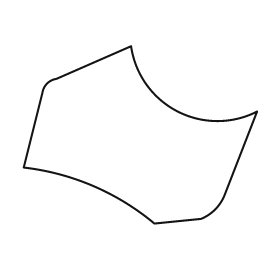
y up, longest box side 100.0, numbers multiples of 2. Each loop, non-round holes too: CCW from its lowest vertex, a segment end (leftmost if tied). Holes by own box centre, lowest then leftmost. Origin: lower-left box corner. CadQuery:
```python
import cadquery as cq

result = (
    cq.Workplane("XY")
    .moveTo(56.0, 0.0)
    .lineTo(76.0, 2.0)
    .threePointArc((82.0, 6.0), (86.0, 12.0))
    .lineTo(100.0, 48.0)
    .threePointArc((66.0, 48.0), (46.0, 76.0))
    .lineTo(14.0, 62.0)
    .threePointArc((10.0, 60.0), (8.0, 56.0))
    .lineTo(0.0, 24.0)
    .threePointArc((30.0, 16.0), (56.0, 0.0))
    .close()
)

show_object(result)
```